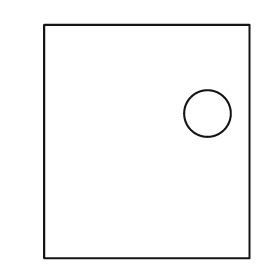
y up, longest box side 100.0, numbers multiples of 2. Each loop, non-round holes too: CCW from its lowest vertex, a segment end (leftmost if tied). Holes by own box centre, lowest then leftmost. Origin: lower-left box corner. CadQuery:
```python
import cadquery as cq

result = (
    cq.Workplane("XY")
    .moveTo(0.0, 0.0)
    .lineTo(88.0, 0.0)
    .lineTo(88.0, 100.0)
    .lineTo(0.0, 100.0)
    .close()
    .moveTo(70.0, 62.0)
    .circle(10.0)
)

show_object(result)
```